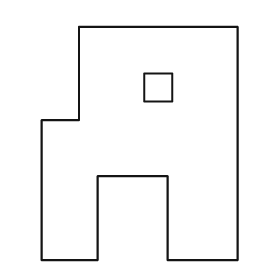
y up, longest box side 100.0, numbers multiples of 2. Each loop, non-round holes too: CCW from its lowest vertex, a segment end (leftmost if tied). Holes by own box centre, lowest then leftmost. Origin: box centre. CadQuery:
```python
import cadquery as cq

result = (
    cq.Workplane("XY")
    .moveTo(-42.0, -50.0)
    .lineTo(-18.0, -50.0)
    .lineTo(-18.0, -14.0)
    .lineTo(12.0, -14.0)
    .lineTo(12.0, -50.0)
    .lineTo(42.0, -50.0)
    .lineTo(42.0, 50.0)
    .lineTo(-26.0, 50.0)
    .lineTo(-26.0, 10.0)
    .lineTo(-42.0, 10.0)
    .close()
    .moveTo(2.0, 18.0)
    .lineTo(14.0, 18.0)
    .lineTo(14.0, 30.0)
    .lineTo(2.0, 30.0)
    .close()
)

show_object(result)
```